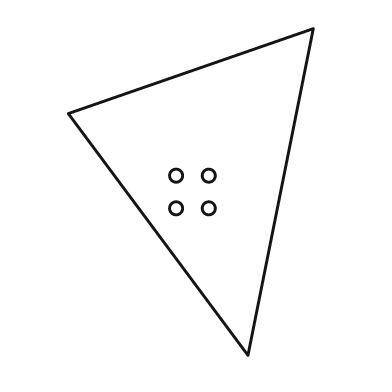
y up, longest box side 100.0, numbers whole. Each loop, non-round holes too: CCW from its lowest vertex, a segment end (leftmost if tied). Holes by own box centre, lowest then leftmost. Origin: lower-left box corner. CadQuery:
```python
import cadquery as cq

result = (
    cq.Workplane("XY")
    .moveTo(55.0, 0.0)
    .lineTo(75.0, 100.0)
    .lineTo(0.0, 74.0)
    .close()
    .moveTo(33.0, 45.0)
    .circle(2.0)
    .moveTo(43.0, 45.0)
    .circle(2.0)
    .moveTo(33.0, 55.0)
    .circle(2.0)
    .moveTo(43.0, 55.0)
    .circle(2.0)
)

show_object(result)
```